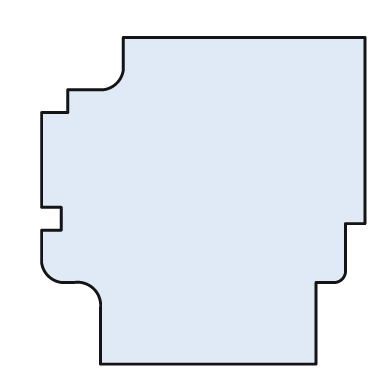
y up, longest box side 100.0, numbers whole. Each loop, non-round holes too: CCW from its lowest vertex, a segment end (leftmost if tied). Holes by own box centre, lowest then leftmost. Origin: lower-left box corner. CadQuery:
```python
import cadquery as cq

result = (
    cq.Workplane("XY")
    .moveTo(18.0, 0.0)
    .lineTo(84.0, 0.0)
    .lineTo(84.0, 25.0)
    .lineTo(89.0, 25.0)
    .threePointArc((92.0, 26.0), (93.0, 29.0))
    .lineTo(93.0, 43.0)
    .lineTo(99.0, 43.0)
    .lineTo(99.0, 100.0)
    .lineTo(25.0, 100.0)
    .lineTo(25.0, 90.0)
    .threePointArc((23.0, 86.0), (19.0, 84.0))
    .lineTo(8.0, 84.0)
    .lineTo(8.0, 77.0)
    .lineTo(0.0, 77.0)
    .lineTo(0.0, 48.0)
    .lineTo(6.0, 48.0)
    .lineTo(6.0, 41.0)
    .lineTo(0.0, 41.0)
    .lineTo(0.0, 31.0)
    .threePointArc((2.0, 27.0), (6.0, 25.0))
    .lineTo(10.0, 25.0)
    .threePointArc((16.0, 23.0), (18.0, 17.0))
    .close()
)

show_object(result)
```